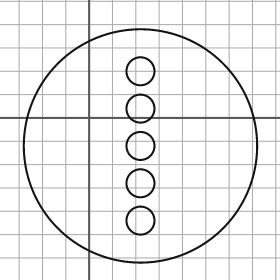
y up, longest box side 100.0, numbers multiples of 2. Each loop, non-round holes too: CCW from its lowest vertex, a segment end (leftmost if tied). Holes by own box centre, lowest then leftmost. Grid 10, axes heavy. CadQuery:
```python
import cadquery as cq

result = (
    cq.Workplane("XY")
    .moveTo(22.0, -12.0)
    .circle(50.0)
    .moveTo(22.0, -44.0)
    .circle(6.0)
    .moveTo(22.0, -28.0)
    .circle(6.0)
    .moveTo(22.0, -12.0)
    .circle(6.0)
    .moveTo(22.0, 4.0)
    .circle(6.0)
    .moveTo(22.0, 20.0)
    .circle(6.0)
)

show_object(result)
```